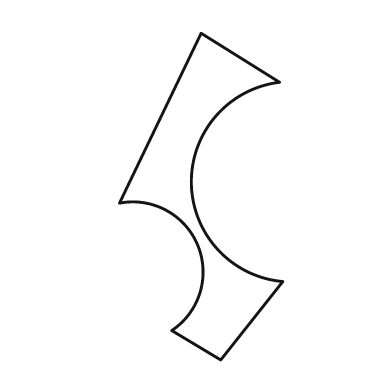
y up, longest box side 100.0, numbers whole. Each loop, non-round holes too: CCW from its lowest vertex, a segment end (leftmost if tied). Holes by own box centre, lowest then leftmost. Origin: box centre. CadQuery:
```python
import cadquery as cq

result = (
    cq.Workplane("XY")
    .moveTo(6.0, -50.0)
    .lineTo(25.0, -26.0)
    .threePointArc((-3.0, 4.0), (24.0, 35.0))
    .lineTo(0.0, 50.0)
    .lineTo(-25.0, -2.0)
    .threePointArc((-1.0, -15.0), (-9.0, -41.0))
    .close()
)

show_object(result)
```